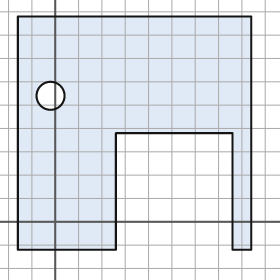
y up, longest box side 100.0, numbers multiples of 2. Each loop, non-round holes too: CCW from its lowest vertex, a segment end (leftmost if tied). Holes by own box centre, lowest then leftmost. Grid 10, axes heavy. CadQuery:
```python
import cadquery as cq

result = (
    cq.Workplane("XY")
    .moveTo(-16.0, -12.0)
    .lineTo(26.0, -12.0)
    .lineTo(26.0, 38.0)
    .lineTo(76.0, 38.0)
    .lineTo(76.0, -12.0)
    .lineTo(84.0, -12.0)
    .lineTo(84.0, 88.0)
    .lineTo(-16.0, 88.0)
    .close()
    .moveTo(-2.0, 54.0)
    .circle(6.0)
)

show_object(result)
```